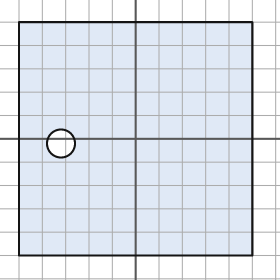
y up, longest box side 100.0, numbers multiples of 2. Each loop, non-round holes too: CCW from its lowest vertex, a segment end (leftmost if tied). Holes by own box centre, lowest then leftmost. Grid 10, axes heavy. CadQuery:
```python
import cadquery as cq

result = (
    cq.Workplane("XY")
    .moveTo(-50.0, -50.0)
    .lineTo(50.0, -50.0)
    .lineTo(50.0, 50.0)
    .lineTo(-50.0, 50.0)
    .close()
    .moveTo(-32.0, -2.0)
    .circle(6.0)
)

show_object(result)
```